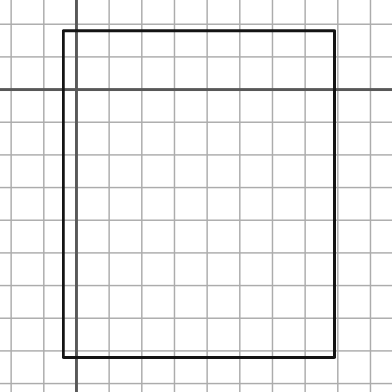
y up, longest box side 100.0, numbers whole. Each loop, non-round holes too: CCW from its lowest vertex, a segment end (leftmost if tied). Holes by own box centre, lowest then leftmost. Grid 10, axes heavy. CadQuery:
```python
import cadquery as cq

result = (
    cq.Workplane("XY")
    .moveTo(-4.0, -82.0)
    .lineTo(79.0, -82.0)
    .lineTo(79.0, 18.0)
    .lineTo(-4.0, 18.0)
    .close()
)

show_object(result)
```